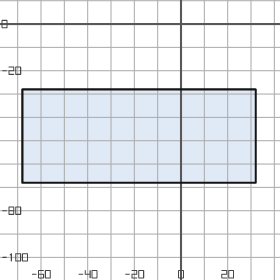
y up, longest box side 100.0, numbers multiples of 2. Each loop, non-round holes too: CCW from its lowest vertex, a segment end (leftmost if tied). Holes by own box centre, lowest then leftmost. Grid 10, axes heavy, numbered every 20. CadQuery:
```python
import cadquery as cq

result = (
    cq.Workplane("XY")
    .moveTo(-68.0, -68.0)
    .lineTo(32.0, -68.0)
    .lineTo(32.0, -28.0)
    .lineTo(-68.0, -28.0)
    .close()
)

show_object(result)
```